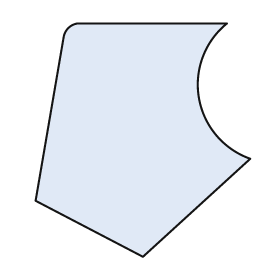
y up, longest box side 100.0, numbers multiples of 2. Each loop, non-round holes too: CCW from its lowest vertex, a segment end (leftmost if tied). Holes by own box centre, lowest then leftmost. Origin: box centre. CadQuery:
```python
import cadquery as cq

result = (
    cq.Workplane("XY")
    .moveTo(0.0, -50.0)
    .lineTo(46.0, -8.0)
    .threePointArc((24.0, 18.0), (36.0, 50.0))
    .lineTo(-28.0, 50.0)
    .threePointArc((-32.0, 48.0), (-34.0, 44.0))
    .lineTo(-46.0, -26.0)
    .close()
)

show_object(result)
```